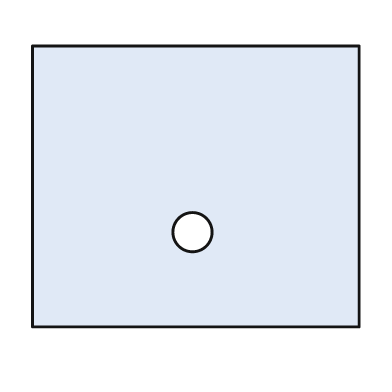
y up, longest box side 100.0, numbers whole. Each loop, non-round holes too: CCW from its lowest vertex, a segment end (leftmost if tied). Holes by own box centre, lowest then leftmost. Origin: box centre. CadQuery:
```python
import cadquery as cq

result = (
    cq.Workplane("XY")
    .moveTo(-50.0, -43.0)
    .lineTo(50.0, -43.0)
    .lineTo(50.0, 43.0)
    .lineTo(-50.0, 43.0)
    .close()
    .moveTo(-1.0, -14.0)
    .circle(6.0)
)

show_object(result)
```